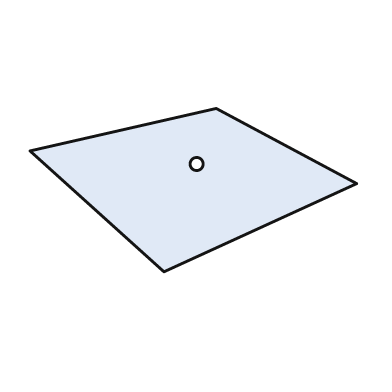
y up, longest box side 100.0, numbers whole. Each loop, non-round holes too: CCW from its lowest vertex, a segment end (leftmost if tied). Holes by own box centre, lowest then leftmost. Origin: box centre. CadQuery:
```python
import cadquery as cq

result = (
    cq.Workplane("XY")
    .moveTo(-9.0, -25.0)
    .lineTo(50.0, 2.0)
    .lineTo(7.0, 25.0)
    .lineTo(-50.0, 12.0)
    .close()
    .moveTo(1.0, 8.0)
    .circle(2.0)
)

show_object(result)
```